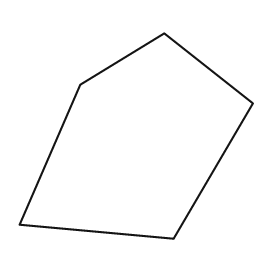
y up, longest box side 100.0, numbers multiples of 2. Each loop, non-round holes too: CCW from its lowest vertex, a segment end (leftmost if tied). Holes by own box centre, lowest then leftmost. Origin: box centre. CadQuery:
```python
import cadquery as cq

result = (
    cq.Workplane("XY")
    .moveTo(16.0, -44.0)
    .lineTo(50.0, 14.0)
    .lineTo(12.0, 44.0)
    .lineTo(-24.0, 22.0)
    .lineTo(-50.0, -38.0)
    .close()
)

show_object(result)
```